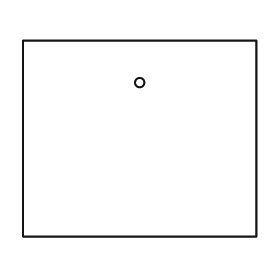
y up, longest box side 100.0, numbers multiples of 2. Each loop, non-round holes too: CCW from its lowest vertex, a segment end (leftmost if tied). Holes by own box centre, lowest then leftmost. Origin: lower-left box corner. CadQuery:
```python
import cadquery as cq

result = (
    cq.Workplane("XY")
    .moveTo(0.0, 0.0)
    .lineTo(100.0, 0.0)
    .lineTo(100.0, 84.0)
    .lineTo(0.0, 84.0)
    .close()
    .moveTo(50.0, 66.0)
    .circle(2.0)
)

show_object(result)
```